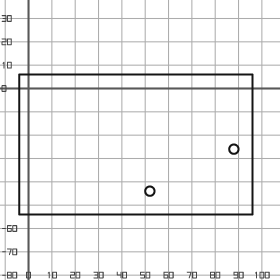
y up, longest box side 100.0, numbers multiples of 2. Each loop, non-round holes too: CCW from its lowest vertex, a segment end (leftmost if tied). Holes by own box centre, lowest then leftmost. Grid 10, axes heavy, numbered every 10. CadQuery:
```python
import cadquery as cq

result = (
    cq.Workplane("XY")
    .moveTo(-4.0, -54.0)
    .lineTo(96.0, -54.0)
    .lineTo(96.0, 6.0)
    .lineTo(-4.0, 6.0)
    .close()
    .moveTo(52.0, -44.0)
    .circle(2.0)
    .moveTo(88.0, -26.0)
    .circle(2.0)
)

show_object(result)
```